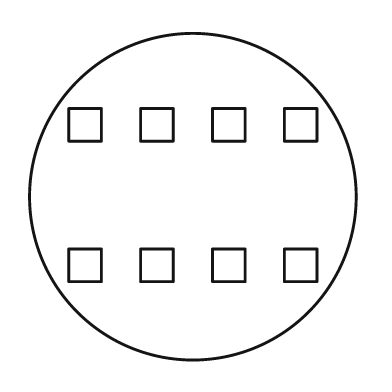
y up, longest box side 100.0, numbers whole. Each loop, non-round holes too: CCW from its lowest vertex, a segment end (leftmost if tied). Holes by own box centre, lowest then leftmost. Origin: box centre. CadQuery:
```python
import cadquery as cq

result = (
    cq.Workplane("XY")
    .moveTo(0.0, 0.0)
    .circle(50.0)
    .moveTo(-38.0, -26.0)
    .lineTo(-28.0, -26.0)
    .lineTo(-28.0, -16.0)
    .lineTo(-38.0, -16.0)
    .close()
    .moveTo(-16.0, -26.0)
    .lineTo(-6.0, -26.0)
    .lineTo(-6.0, -16.0)
    .lineTo(-16.0, -16.0)
    .close()
    .moveTo(6.0, -26.0)
    .lineTo(16.0, -26.0)
    .lineTo(16.0, -16.0)
    .lineTo(6.0, -16.0)
    .close()
    .moveTo(28.0, -26.0)
    .lineTo(38.0, -26.0)
    .lineTo(38.0, -16.0)
    .lineTo(28.0, -16.0)
    .close()
    .moveTo(-38.0, 17.0)
    .lineTo(-28.0, 17.0)
    .lineTo(-28.0, 27.0)
    .lineTo(-38.0, 27.0)
    .close()
    .moveTo(-16.0, 17.0)
    .lineTo(-6.0, 17.0)
    .lineTo(-6.0, 27.0)
    .lineTo(-16.0, 27.0)
    .close()
    .moveTo(6.0, 17.0)
    .lineTo(16.0, 17.0)
    .lineTo(16.0, 27.0)
    .lineTo(6.0, 27.0)
    .close()
    .moveTo(28.0, 17.0)
    .lineTo(38.0, 17.0)
    .lineTo(38.0, 27.0)
    .lineTo(28.0, 27.0)
    .close()
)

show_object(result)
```